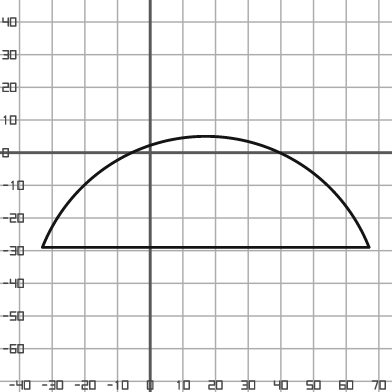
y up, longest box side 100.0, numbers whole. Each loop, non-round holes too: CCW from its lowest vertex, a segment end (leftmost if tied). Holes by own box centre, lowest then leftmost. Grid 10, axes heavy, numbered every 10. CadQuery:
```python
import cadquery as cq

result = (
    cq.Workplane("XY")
    .moveTo(-33.0, -29.0)
    .lineTo(67.0, -29.0)
    .threePointArc((17.0, 5.0), (-33.0, -29.0))
    .close()
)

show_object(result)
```